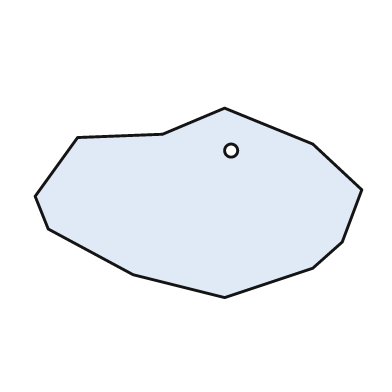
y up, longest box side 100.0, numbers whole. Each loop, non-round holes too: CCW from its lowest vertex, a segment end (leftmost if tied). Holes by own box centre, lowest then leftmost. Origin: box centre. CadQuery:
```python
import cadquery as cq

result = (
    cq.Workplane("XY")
    .moveTo(8.0, -29.0)
    .lineTo(35.0, -20.0)
    .lineTo(44.0, -12.0)
    .lineTo(50.0, 4.0)
    .lineTo(35.0, 18.0)
    .lineTo(8.0, 29.0)
    .lineTo(-11.0, 21.0)
    .lineTo(-37.0, 20.0)
    .lineTo(-50.0, 2.0)
    .lineTo(-46.0, -8.0)
    .lineTo(-20.0, -22.0)
    .close()
    .moveTo(10.0, 16.0)
    .circle(2.0)
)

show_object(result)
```